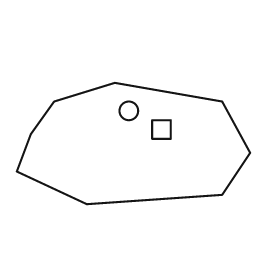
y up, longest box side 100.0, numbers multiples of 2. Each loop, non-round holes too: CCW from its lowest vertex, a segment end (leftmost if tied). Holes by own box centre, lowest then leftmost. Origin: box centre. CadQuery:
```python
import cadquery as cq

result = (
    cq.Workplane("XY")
    .moveTo(-20.0, -26.0)
    .lineTo(38.0, -22.0)
    .lineTo(50.0, -4.0)
    .lineTo(38.0, 18.0)
    .lineTo(-8.0, 26.0)
    .lineTo(-34.0, 18.0)
    .lineTo(-44.0, 4.0)
    .lineTo(-50.0, -12.0)
    .close()
    .moveTo(8.0, 2.0)
    .lineTo(16.0, 2.0)
    .lineTo(16.0, 10.0)
    .lineTo(8.0, 10.0)
    .close()
    .moveTo(-2.0, 14.0)
    .circle(4.0)
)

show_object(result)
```